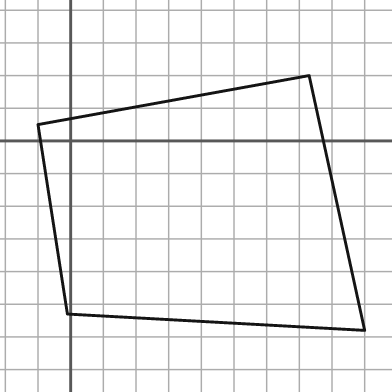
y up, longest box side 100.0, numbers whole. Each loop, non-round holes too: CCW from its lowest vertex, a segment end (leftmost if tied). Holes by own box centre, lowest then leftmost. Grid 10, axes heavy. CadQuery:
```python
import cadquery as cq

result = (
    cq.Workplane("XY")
    .moveTo(90.0, -58.0)
    .lineTo(73.0, 20.0)
    .lineTo(-10.0, 5.0)
    .lineTo(-1.0, -53.0)
    .close()
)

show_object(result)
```